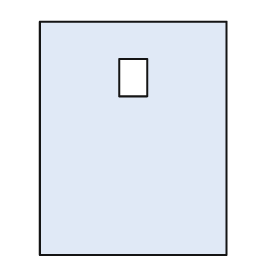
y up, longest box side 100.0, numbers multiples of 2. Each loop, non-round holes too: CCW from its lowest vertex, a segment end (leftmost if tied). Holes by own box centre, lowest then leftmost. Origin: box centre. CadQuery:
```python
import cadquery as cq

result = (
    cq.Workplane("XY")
    .moveTo(-40.0, -50.0)
    .lineTo(40.0, -50.0)
    .lineTo(40.0, 50.0)
    .lineTo(-40.0, 50.0)
    .close()
    .moveTo(-6.0, 18.0)
    .lineTo(6.0, 18.0)
    .lineTo(6.0, 34.0)
    .lineTo(-6.0, 34.0)
    .close()
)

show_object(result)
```